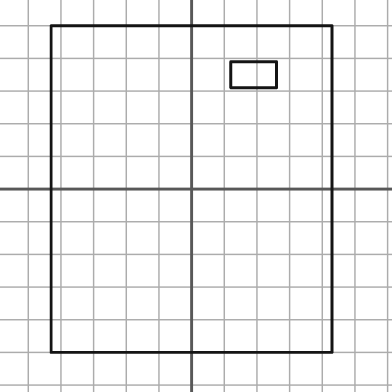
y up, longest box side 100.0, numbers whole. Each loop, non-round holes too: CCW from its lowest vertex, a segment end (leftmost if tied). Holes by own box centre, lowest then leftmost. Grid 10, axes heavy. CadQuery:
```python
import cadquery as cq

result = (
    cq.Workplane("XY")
    .moveTo(-43.0, -50.0)
    .lineTo(43.0, -50.0)
    .lineTo(43.0, 50.0)
    .lineTo(-43.0, 50.0)
    .close()
    .moveTo(12.0, 31.0)
    .lineTo(26.0, 31.0)
    .lineTo(26.0, 39.0)
    .lineTo(12.0, 39.0)
    .close()
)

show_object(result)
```